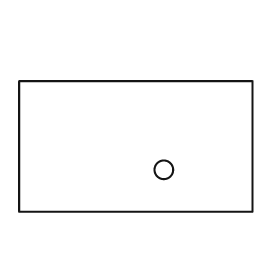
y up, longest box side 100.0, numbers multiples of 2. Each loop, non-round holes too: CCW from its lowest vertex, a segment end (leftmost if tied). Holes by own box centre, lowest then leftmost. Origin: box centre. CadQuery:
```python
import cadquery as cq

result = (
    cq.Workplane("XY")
    .moveTo(-50.0, -28.0)
    .lineTo(50.0, -28.0)
    .lineTo(50.0, 28.0)
    .lineTo(-50.0, 28.0)
    .close()
    .moveTo(12.0, -10.0)
    .circle(4.0)
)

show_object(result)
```